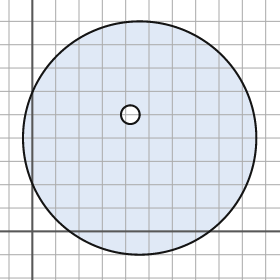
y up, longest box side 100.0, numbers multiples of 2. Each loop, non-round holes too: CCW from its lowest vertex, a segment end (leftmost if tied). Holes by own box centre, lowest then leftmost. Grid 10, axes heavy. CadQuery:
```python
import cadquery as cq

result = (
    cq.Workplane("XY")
    .moveTo(46.0, 40.0)
    .circle(50.0)
    .moveTo(42.0, 50.0)
    .circle(4.0)
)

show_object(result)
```